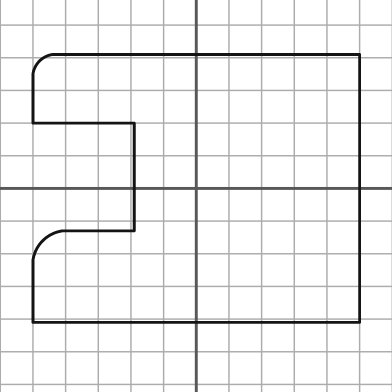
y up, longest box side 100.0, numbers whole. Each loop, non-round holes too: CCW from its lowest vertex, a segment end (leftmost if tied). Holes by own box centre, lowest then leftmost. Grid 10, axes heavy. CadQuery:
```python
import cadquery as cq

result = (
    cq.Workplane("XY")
    .moveTo(-50.0, -41.0)
    .lineTo(50.0, -41.0)
    .lineTo(50.0, 41.0)
    .lineTo(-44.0, 41.0)
    .threePointArc((-48.0, 39.0), (-50.0, 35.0))
    .lineTo(-50.0, 20.0)
    .lineTo(-19.0, 20.0)
    .lineTo(-19.0, -13.0)
    .lineTo(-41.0, -13.0)
    .threePointArc((-47.0, -16.0), (-50.0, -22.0))
    .close()
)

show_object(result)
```